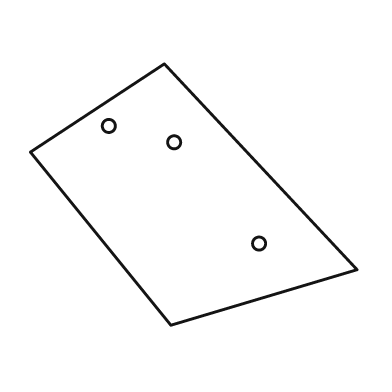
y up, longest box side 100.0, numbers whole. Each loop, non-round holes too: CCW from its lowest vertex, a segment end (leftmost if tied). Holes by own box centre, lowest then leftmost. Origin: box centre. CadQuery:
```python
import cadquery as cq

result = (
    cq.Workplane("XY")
    .moveTo(-7.0, -40.0)
    .lineTo(50.0, -23.0)
    .lineTo(-9.0, 40.0)
    .lineTo(-50.0, 13.0)
    .close()
    .moveTo(20.0, -15.0)
    .circle(2.0)
    .moveTo(-6.0, 16.0)
    .circle(2.0)
    .moveTo(-26.0, 21.0)
    .circle(2.0)
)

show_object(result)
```